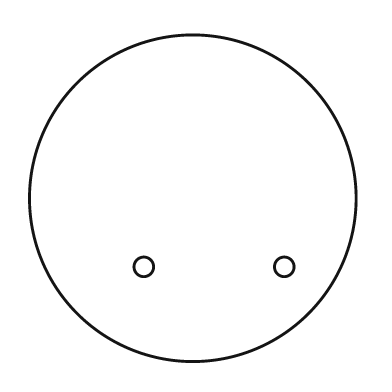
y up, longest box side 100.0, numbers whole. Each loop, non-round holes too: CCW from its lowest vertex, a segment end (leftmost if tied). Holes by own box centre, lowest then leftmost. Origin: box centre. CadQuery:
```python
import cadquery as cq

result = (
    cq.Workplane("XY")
    .moveTo(0.0, 0.0)
    .circle(50.0)
    .moveTo(-15.0, -21.0)
    .circle(3.0)
    .moveTo(28.0, -21.0)
    .circle(3.0)
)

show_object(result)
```